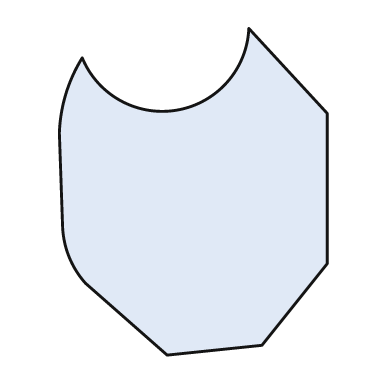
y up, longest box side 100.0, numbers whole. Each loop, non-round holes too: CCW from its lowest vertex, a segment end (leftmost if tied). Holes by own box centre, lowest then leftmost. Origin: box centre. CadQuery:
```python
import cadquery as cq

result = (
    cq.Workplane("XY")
    .moveTo(-8.0, -50.0)
    .lineTo(21.0, -47.0)
    .lineTo(41.0, -22.0)
    .lineTo(41.0, 24.0)
    .lineTo(17.0, 50.0)
    .threePointArc((-5.0, 25.0), (-34.0, 41.0))
    .threePointArc((-39.0, 30.0), (-41.0, 18.0))
    .lineTo(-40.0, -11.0)
    .threePointArc((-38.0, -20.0), (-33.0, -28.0))
    .close()
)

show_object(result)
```